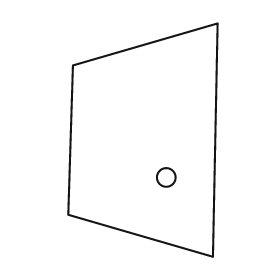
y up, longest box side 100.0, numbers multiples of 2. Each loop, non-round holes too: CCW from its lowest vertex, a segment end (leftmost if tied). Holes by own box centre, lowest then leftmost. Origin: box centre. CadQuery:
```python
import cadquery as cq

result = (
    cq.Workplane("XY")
    .moveTo(30.0, -50.0)
    .lineTo(32.0, 50.0)
    .lineTo(-30.0, 32.0)
    .lineTo(-32.0, -32.0)
    .close()
    .moveTo(10.0, -16.0)
    .circle(4.0)
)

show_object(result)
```